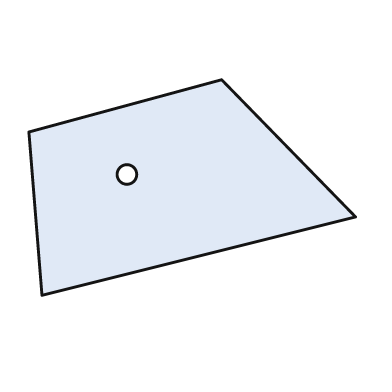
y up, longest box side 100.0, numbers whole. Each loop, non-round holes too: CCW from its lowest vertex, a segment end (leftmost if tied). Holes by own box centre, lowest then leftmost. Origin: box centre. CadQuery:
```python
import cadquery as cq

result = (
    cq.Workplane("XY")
    .moveTo(-46.0, -33.0)
    .lineTo(50.0, -9.0)
    .lineTo(9.0, 33.0)
    .lineTo(-50.0, 17.0)
    .close()
    .moveTo(-20.0, 4.0)
    .circle(3.0)
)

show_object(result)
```